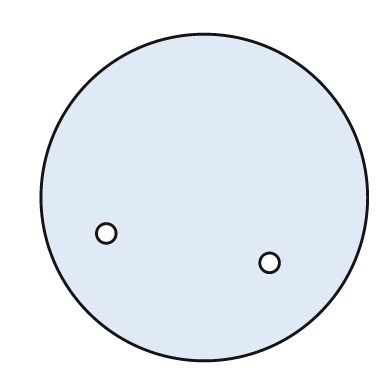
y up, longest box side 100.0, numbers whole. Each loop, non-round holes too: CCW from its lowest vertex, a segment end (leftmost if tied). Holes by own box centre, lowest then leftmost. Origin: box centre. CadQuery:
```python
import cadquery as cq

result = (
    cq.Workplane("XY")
    .moveTo(0.0, 0.0)
    .circle(50.0)
    .moveTo(20.0, -20.0)
    .circle(3.0)
    .moveTo(-30.0, -11.0)
    .circle(3.0)
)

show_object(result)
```